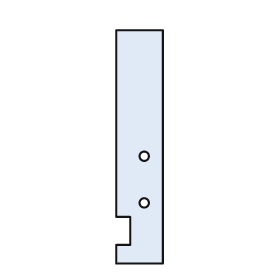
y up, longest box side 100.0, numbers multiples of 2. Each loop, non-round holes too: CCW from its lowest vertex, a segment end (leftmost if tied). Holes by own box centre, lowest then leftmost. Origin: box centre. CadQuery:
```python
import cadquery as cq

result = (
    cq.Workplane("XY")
    .moveTo(-10.0, -50.0)
    .lineTo(10.0, -50.0)
    .lineTo(10.0, 50.0)
    .lineTo(-10.0, 50.0)
    .lineTo(-10.0, -30.0)
    .lineTo(-4.0, -30.0)
    .lineTo(-4.0, -42.0)
    .lineTo(-10.0, -42.0)
    .close()
    .moveTo(2.0, -24.0)
    .circle(2.0)
    .moveTo(2.0, -4.0)
    .circle(2.0)
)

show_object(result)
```